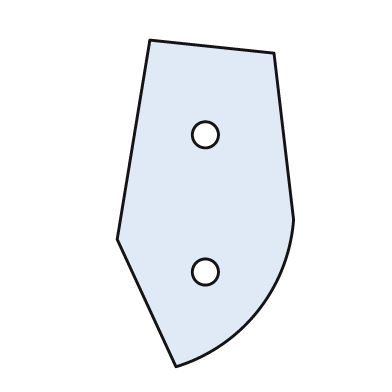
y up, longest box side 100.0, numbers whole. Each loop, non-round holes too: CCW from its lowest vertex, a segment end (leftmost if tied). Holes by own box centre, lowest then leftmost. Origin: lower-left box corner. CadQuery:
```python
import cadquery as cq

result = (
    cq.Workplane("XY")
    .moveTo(18.0, 0.0)
    .threePointArc((43.0, 17.0), (54.0, 45.0))
    .lineTo(48.0, 96.0)
    .lineTo(10.0, 100.0)
    .lineTo(0.0, 39.0)
    .close()
    .moveTo(27.0, 29.0)
    .circle(4.0)
    .moveTo(27.0, 71.0)
    .circle(4.0)
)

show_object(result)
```